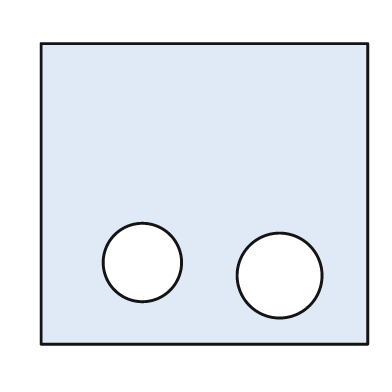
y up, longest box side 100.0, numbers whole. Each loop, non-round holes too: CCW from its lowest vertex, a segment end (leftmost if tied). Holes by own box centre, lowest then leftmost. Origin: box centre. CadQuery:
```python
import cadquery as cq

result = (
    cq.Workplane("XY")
    .moveTo(-50.0, -46.0)
    .lineTo(50.0, -46.0)
    .lineTo(50.0, 46.0)
    .lineTo(-50.0, 46.0)
    .close()
    .moveTo(23.0, -25.0)
    .circle(13.0)
    .moveTo(-19.0, -21.0)
    .circle(12.0)
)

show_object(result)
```